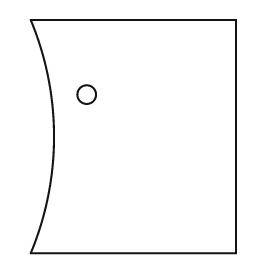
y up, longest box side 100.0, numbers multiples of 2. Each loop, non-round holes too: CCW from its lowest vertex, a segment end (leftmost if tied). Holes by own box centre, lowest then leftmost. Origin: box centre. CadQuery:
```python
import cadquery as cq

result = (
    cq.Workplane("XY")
    .moveTo(-44.0, -50.0)
    .lineTo(44.0, -50.0)
    .lineTo(44.0, 50.0)
    .lineTo(-44.0, 50.0)
    .threePointArc((-34.0, 0.0), (-44.0, -50.0))
    .close()
    .moveTo(-20.0, 18.0)
    .circle(4.0)
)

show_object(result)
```